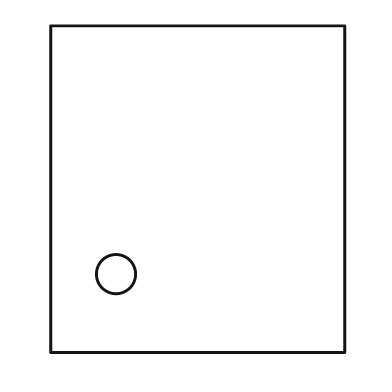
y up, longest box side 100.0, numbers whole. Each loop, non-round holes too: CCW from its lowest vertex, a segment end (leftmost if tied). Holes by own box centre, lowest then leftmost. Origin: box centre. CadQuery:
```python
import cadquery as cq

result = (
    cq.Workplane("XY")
    .moveTo(-45.0, -50.0)
    .lineTo(45.0, -50.0)
    .lineTo(45.0, 50.0)
    .lineTo(-45.0, 50.0)
    .close()
    .moveTo(-25.0, -26.0)
    .circle(6.0)
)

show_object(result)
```